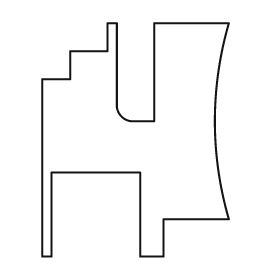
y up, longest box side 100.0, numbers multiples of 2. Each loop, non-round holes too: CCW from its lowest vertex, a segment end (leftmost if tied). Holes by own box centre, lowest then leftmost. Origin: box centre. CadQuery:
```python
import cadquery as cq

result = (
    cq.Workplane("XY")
    .moveTo(-40.0, -50.0)
    .lineTo(-36.0, -50.0)
    .lineTo(-36.0, -14.0)
    .lineTo(2.0, -14.0)
    .lineTo(2.0, -50.0)
    .lineTo(12.0, -50.0)
    .lineTo(12.0, -34.0)
    .lineTo(40.0, -34.0)
    .threePointArc((34.0, 8.0), (40.0, 50.0))
    .lineTo(8.0, 50.0)
    .lineTo(8.0, 8.0)
    .lineTo(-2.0, 8.0)
    .threePointArc((-6.0, 10.0), (-8.0, 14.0))
    .lineTo(-8.0, 50.0)
    .lineTo(-12.0, 50.0)
    .lineTo(-12.0, 38.0)
    .lineTo(-28.0, 38.0)
    .lineTo(-28.0, 26.0)
    .lineTo(-40.0, 26.0)
    .close()
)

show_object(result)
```